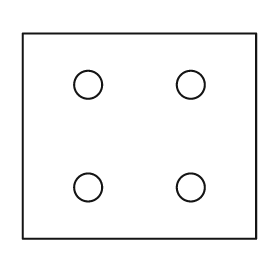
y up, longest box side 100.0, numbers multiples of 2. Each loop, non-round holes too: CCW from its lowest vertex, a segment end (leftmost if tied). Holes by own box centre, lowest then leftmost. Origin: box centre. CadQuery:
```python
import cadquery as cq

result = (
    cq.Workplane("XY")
    .moveTo(-50.0, -44.0)
    .lineTo(50.0, -44.0)
    .lineTo(50.0, 44.0)
    .lineTo(-50.0, 44.0)
    .close()
    .moveTo(-22.0, -22.0)
    .circle(6.0)
    .moveTo(22.0, -22.0)
    .circle(6.0)
    .moveTo(-22.0, 22.0)
    .circle(6.0)
    .moveTo(22.0, 22.0)
    .circle(6.0)
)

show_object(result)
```